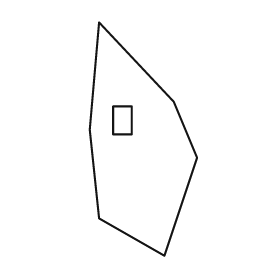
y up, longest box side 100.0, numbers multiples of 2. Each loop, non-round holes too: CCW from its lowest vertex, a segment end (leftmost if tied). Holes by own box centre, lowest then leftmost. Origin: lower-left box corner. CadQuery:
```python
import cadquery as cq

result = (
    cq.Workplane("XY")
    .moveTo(32.0, 0.0)
    .lineTo(46.0, 42.0)
    .lineTo(36.0, 66.0)
    .lineTo(4.0, 100.0)
    .lineTo(0.0, 54.0)
    .lineTo(4.0, 16.0)
    .close()
    .moveTo(10.0, 52.0)
    .lineTo(18.0, 52.0)
    .lineTo(18.0, 64.0)
    .lineTo(10.0, 64.0)
    .close()
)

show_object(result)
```